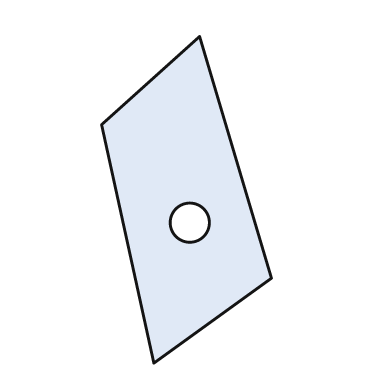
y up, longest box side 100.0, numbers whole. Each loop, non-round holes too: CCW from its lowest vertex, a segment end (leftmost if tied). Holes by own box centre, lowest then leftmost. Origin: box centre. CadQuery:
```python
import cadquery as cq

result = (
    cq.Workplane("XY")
    .moveTo(-10.0, -50.0)
    .lineTo(26.0, -24.0)
    .lineTo(4.0, 50.0)
    .lineTo(-26.0, 23.0)
    .close()
    .moveTo(1.0, -7.0)
    .circle(6.0)
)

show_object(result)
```